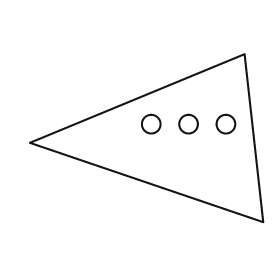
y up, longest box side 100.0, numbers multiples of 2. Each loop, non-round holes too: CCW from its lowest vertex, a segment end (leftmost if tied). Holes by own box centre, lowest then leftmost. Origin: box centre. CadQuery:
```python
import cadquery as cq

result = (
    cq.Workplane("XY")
    .moveTo(50.0, -36.0)
    .lineTo(42.0, 36.0)
    .lineTo(-50.0, -2.0)
    .close()
    .moveTo(2.0, 6.0)
    .circle(4.0)
    .moveTo(18.0, 6.0)
    .circle(4.0)
    .moveTo(34.0, 6.0)
    .circle(4.0)
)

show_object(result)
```